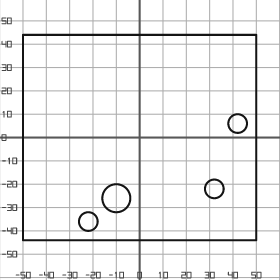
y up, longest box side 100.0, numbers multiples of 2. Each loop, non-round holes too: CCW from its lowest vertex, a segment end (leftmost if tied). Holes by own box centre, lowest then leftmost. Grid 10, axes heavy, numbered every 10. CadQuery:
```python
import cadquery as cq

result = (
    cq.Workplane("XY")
    .moveTo(-50.0, -44.0)
    .lineTo(50.0, -44.0)
    .lineTo(50.0, 44.0)
    .lineTo(-50.0, 44.0)
    .close()
    .moveTo(-22.0, -36.0)
    .circle(4.0)
    .moveTo(-10.0, -26.0)
    .circle(6.0)
    .moveTo(32.0, -22.0)
    .circle(4.0)
    .moveTo(42.0, 6.0)
    .circle(4.0)
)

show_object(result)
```